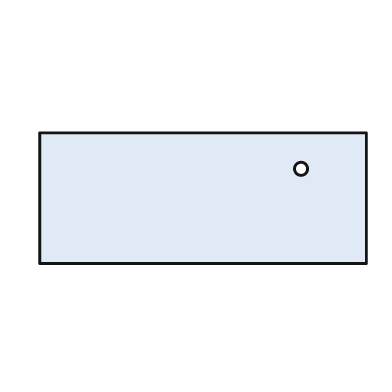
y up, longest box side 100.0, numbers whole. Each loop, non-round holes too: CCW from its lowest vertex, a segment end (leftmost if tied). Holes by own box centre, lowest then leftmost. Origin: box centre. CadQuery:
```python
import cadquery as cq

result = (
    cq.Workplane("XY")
    .moveTo(-50.0, -20.0)
    .lineTo(50.0, -20.0)
    .lineTo(50.0, 20.0)
    .lineTo(-50.0, 20.0)
    .close()
    .moveTo(30.0, 9.0)
    .circle(2.0)
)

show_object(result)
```